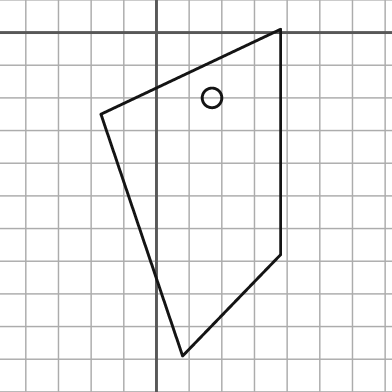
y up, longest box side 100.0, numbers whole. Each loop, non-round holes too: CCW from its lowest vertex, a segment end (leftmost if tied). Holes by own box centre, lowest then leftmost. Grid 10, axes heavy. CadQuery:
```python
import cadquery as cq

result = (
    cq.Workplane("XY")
    .moveTo(8.0, -99.0)
    .lineTo(38.0, -68.0)
    .lineTo(38.0, 1.0)
    .lineTo(-17.0, -25.0)
    .close()
    .moveTo(17.0, -20.0)
    .circle(3.0)
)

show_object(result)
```